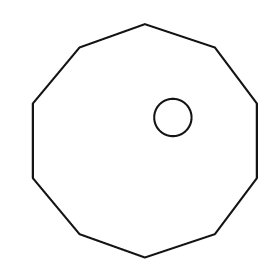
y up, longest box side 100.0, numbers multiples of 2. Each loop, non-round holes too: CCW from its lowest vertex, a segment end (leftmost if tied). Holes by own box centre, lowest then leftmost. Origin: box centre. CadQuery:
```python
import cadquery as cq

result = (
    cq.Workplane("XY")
    .moveTo(0.0, -50.0)
    .lineTo(30.0, -40.0)
    .lineTo(48.0, -16.0)
    .lineTo(48.0, 16.0)
    .lineTo(30.0, 40.0)
    .lineTo(0.0, 50.0)
    .lineTo(-28.0, 40.0)
    .lineTo(-48.0, 16.0)
    .lineTo(-48.0, -16.0)
    .lineTo(-28.0, -40.0)
    .close()
    .moveTo(12.0, 10.0)
    .circle(8.0)
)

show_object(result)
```